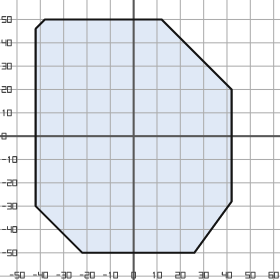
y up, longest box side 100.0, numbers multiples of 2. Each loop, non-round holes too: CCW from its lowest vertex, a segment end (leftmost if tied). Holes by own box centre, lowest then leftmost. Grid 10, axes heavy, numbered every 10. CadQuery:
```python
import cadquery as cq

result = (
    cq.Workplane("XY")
    .moveTo(-22.0, -50.0)
    .lineTo(26.0, -50.0)
    .lineTo(42.0, -28.0)
    .lineTo(42.0, 20.0)
    .lineTo(12.0, 50.0)
    .lineTo(-38.0, 50.0)
    .lineTo(-42.0, 46.0)
    .lineTo(-42.0, -30.0)
    .close()
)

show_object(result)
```